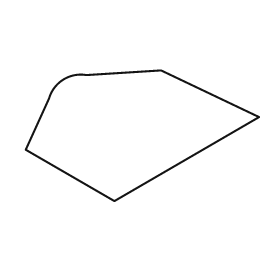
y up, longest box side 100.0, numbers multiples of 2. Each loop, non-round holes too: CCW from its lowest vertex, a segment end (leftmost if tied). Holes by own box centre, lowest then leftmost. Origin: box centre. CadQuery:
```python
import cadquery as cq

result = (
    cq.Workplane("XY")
    .moveTo(-12.0, -28.0)
    .lineTo(50.0, 8.0)
    .lineTo(8.0, 28.0)
    .lineTo(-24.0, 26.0)
    .threePointArc((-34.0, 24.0), (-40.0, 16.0))
    .lineTo(-50.0, -6.0)
    .close()
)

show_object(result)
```